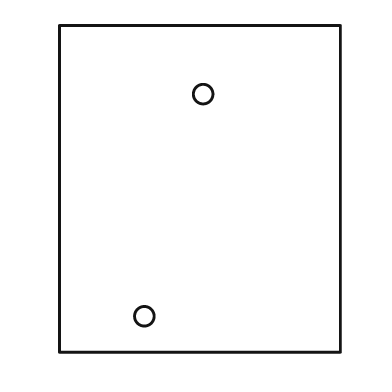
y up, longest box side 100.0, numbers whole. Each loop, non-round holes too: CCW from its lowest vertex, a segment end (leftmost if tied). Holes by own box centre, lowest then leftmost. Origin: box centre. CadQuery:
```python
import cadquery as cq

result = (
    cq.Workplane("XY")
    .moveTo(-43.0, -50.0)
    .lineTo(43.0, -50.0)
    .lineTo(43.0, 50.0)
    .lineTo(-43.0, 50.0)
    .close()
    .moveTo(-17.0, -39.0)
    .circle(3.0)
    .moveTo(1.0, 29.0)
    .circle(3.0)
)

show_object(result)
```